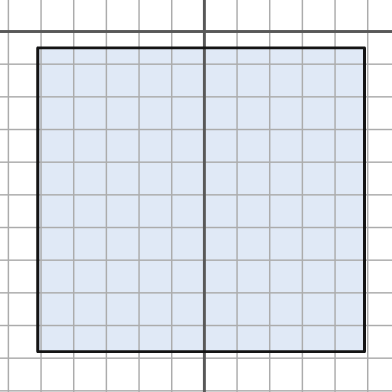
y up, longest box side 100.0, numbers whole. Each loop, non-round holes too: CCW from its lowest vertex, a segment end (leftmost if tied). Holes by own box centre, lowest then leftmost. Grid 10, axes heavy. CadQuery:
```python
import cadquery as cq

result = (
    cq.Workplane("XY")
    .moveTo(-51.0, -98.0)
    .lineTo(49.0, -98.0)
    .lineTo(49.0, -5.0)
    .lineTo(-51.0, -5.0)
    .close()
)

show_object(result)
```